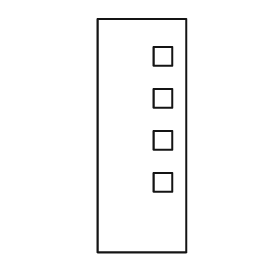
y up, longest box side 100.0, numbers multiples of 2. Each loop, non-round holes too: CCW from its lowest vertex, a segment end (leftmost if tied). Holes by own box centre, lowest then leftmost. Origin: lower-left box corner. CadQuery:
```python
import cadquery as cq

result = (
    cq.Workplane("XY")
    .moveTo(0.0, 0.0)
    .lineTo(38.0, 0.0)
    .lineTo(38.0, 100.0)
    .lineTo(0.0, 100.0)
    .close()
    .moveTo(24.0, 26.0)
    .lineTo(32.0, 26.0)
    .lineTo(32.0, 34.0)
    .lineTo(24.0, 34.0)
    .close()
    .moveTo(24.0, 44.0)
    .lineTo(32.0, 44.0)
    .lineTo(32.0, 52.0)
    .lineTo(24.0, 52.0)
    .close()
    .moveTo(24.0, 62.0)
    .lineTo(32.0, 62.0)
    .lineTo(32.0, 70.0)
    .lineTo(24.0, 70.0)
    .close()
    .moveTo(24.0, 80.0)
    .lineTo(32.0, 80.0)
    .lineTo(32.0, 88.0)
    .lineTo(24.0, 88.0)
    .close()
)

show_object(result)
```